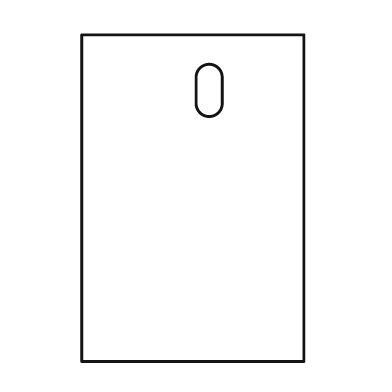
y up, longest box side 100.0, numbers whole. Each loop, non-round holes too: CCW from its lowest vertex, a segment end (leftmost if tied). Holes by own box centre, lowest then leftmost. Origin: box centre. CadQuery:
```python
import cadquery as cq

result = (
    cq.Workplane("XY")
    .moveTo(-34.0, -50.0)
    .lineTo(34.0, -50.0)
    .lineTo(34.0, 50.0)
    .lineTo(-34.0, 50.0)
    .close()
    .moveTo(1.0, 29.0)
    .threePointArc((5.0, 25.0), (9.0, 29.0))
    .lineTo(9.0, 37.0)
    .threePointArc((5.0, 41.0), (1.0, 37.0))
    .close()
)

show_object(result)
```